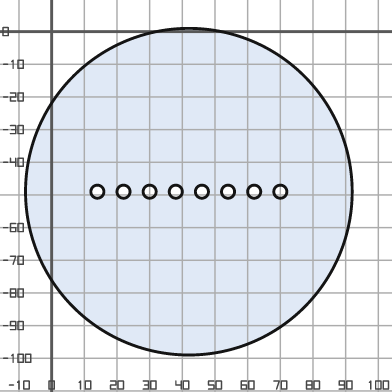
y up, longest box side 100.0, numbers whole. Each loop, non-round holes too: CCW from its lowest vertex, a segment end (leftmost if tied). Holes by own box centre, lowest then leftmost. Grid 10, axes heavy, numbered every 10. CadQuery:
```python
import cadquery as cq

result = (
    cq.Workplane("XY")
    .moveTo(42.0, -49.0)
    .circle(50.0)
    .moveTo(14.0, -49.0)
    .circle(2.0)
    .moveTo(22.0, -49.0)
    .circle(2.0)
    .moveTo(30.0, -49.0)
    .circle(2.0)
    .moveTo(38.0, -49.0)
    .circle(2.0)
    .moveTo(46.0, -49.0)
    .circle(2.0)
    .moveTo(54.0, -49.0)
    .circle(2.0)
    .moveTo(62.0, -49.0)
    .circle(2.0)
    .moveTo(70.0, -49.0)
    .circle(2.0)
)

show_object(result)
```